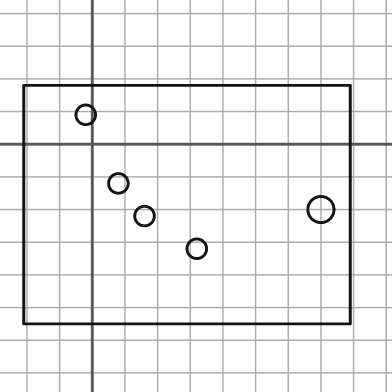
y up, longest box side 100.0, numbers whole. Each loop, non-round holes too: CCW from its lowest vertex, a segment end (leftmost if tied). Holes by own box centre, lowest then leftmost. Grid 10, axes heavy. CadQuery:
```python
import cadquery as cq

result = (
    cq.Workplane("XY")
    .moveTo(-21.0, -55.0)
    .lineTo(79.0, -55.0)
    .lineTo(79.0, 18.0)
    .lineTo(-21.0, 18.0)
    .close()
    .moveTo(32.0, -32.0)
    .circle(3.0)
    .moveTo(16.0, -22.0)
    .circle(3.0)
    .moveTo(70.0, -20.0)
    .circle(4.0)
    .moveTo(8.0, -12.0)
    .circle(3.0)
    .moveTo(-2.0, 9.0)
    .circle(3.0)
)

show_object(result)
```